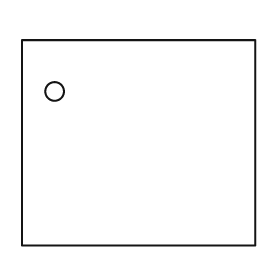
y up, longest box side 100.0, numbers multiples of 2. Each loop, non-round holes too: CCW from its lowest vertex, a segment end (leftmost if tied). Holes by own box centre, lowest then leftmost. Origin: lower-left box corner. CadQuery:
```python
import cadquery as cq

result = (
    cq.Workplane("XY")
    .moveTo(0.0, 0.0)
    .lineTo(100.0, 0.0)
    .lineTo(100.0, 88.0)
    .lineTo(0.0, 88.0)
    .close()
    .moveTo(14.0, 66.0)
    .circle(4.0)
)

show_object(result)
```